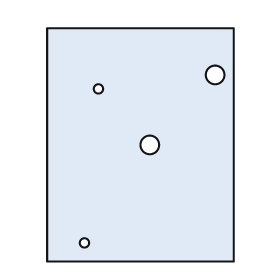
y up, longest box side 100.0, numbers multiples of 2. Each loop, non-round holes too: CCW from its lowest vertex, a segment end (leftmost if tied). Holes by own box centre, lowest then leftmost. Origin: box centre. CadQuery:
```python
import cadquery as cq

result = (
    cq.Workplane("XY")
    .moveTo(-40.0, -50.0)
    .lineTo(40.0, -50.0)
    .lineTo(40.0, 50.0)
    .lineTo(-40.0, 50.0)
    .close()
    .moveTo(-24.0, -42.0)
    .circle(2.0)
    .moveTo(4.0, 0.0)
    .circle(4.0)
    .moveTo(-18.0, 24.0)
    .circle(2.0)
    .moveTo(32.0, 30.0)
    .circle(4.0)
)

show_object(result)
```